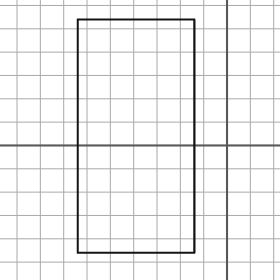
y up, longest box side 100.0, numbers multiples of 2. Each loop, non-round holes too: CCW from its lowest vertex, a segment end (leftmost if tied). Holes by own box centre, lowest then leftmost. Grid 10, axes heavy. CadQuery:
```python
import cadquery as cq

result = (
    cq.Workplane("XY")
    .moveTo(-64.0, -46.0)
    .lineTo(-14.0, -46.0)
    .lineTo(-14.0, 54.0)
    .lineTo(-64.0, 54.0)
    .close()
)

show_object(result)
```